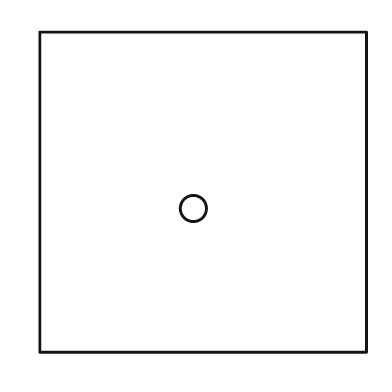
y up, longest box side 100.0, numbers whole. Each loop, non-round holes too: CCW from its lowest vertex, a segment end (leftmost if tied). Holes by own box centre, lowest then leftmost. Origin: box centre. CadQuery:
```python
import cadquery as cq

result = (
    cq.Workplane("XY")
    .moveTo(-50.0, -49.0)
    .lineTo(50.0, -49.0)
    .lineTo(50.0, 49.0)
    .lineTo(-50.0, 49.0)
    .close()
    .moveTo(-3.0, -5.0)
    .circle(4.0)
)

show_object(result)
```